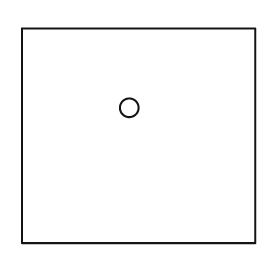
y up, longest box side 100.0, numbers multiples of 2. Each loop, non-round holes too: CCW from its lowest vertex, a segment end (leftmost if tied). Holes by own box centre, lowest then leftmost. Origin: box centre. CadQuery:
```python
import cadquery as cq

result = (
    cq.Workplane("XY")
    .moveTo(-50.0, -46.0)
    .lineTo(50.0, -46.0)
    .lineTo(50.0, 46.0)
    .lineTo(-50.0, 46.0)
    .close()
    .moveTo(-4.0, 12.0)
    .circle(4.0)
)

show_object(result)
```